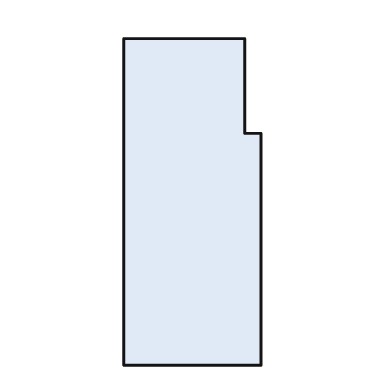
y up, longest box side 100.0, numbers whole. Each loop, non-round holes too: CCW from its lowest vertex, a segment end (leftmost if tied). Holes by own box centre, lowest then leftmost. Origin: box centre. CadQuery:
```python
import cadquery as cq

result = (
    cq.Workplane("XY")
    .moveTo(-21.0, -50.0)
    .lineTo(21.0, -50.0)
    .lineTo(21.0, 21.0)
    .lineTo(16.0, 21.0)
    .lineTo(16.0, 50.0)
    .lineTo(-21.0, 50.0)
    .close()
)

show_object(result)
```